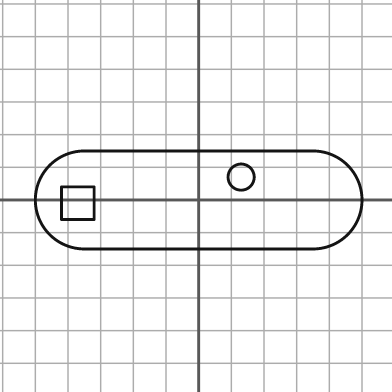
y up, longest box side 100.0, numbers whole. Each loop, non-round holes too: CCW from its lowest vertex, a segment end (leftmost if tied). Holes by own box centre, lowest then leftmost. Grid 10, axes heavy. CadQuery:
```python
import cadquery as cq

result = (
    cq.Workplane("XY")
    .moveTo(-35.0, -15.0)
    .lineTo(35.0, -15.0)
    .threePointArc((50.0, 0.0), (35.0, 15.0))
    .lineTo(-35.0, 15.0)
    .threePointArc((-50.0, 0.0), (-35.0, -15.0))
    .close()
    .moveTo(-42.0, -6.0)
    .lineTo(-32.0, -6.0)
    .lineTo(-32.0, 4.0)
    .lineTo(-42.0, 4.0)
    .close()
    .moveTo(13.0, 7.0)
    .circle(4.0)
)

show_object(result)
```